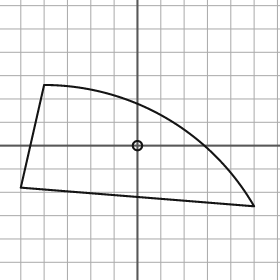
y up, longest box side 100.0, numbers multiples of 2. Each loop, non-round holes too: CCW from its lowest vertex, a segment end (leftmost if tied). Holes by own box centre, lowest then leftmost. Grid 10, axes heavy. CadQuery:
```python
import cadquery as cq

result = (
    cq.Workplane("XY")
    .moveTo(50.0, -26.0)
    .threePointArc((12.0, 12.0), (-40.0, 26.0))
    .lineTo(-50.0, -18.0)
    .close()
    .moveTo(0.0, 0.0)
    .circle(2.0)
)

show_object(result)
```